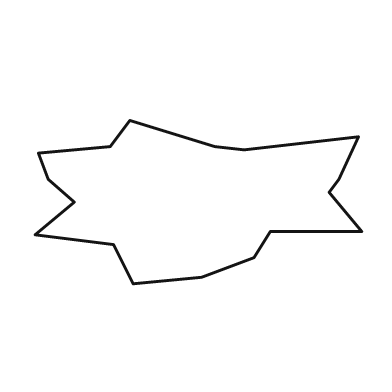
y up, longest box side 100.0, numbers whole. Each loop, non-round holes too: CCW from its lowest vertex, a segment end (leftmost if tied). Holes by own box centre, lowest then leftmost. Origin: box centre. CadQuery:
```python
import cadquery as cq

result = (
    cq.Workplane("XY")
    .moveTo(-20.0, -25.0)
    .lineTo(1.0, -23.0)
    .lineTo(17.0, -17.0)
    .lineTo(22.0, -9.0)
    .lineTo(50.0, -9.0)
    .lineTo(40.0, 3.0)
    .lineTo(43.0, 7.0)
    .lineTo(49.0, 20.0)
    .lineTo(14.0, 16.0)
    .lineTo(5.0, 17.0)
    .lineTo(-21.0, 25.0)
    .lineTo(-27.0, 17.0)
    .lineTo(-49.0, 15.0)
    .lineTo(-46.0, 7.0)
    .lineTo(-38.0, 0.0)
    .lineTo(-50.0, -10.0)
    .lineTo(-26.0, -13.0)
    .close()
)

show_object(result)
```